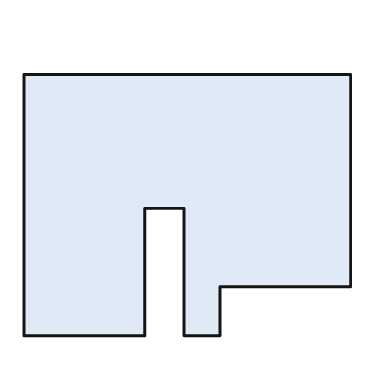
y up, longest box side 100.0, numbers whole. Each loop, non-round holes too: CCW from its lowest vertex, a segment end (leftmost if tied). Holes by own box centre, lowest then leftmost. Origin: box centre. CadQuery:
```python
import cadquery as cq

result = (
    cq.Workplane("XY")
    .moveTo(-50.0, -40.0)
    .lineTo(-13.0, -40.0)
    .lineTo(-13.0, -1.0)
    .lineTo(-1.0, -1.0)
    .lineTo(-1.0, -40.0)
    .lineTo(10.0, -40.0)
    .lineTo(10.0, -25.0)
    .lineTo(50.0, -25.0)
    .lineTo(50.0, 40.0)
    .lineTo(-50.0, 40.0)
    .close()
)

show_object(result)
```